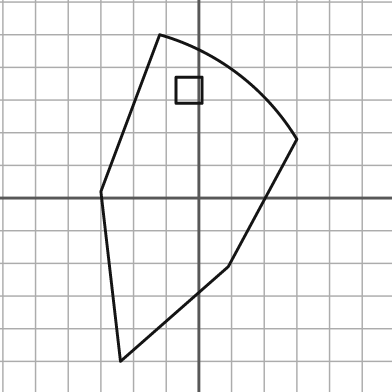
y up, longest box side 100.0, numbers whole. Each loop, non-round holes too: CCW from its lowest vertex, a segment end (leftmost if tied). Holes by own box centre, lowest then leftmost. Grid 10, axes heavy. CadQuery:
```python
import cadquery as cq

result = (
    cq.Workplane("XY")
    .moveTo(-24.0, -50.0)
    .lineTo(9.0, -21.0)
    .lineTo(30.0, 18.0)
    .threePointArc((12.0, 38.0), (-12.0, 50.0))
    .lineTo(-30.0, 2.0)
    .close()
    .moveTo(-7.0, 29.0)
    .lineTo(1.0, 29.0)
    .lineTo(1.0, 37.0)
    .lineTo(-7.0, 37.0)
    .close()
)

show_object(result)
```